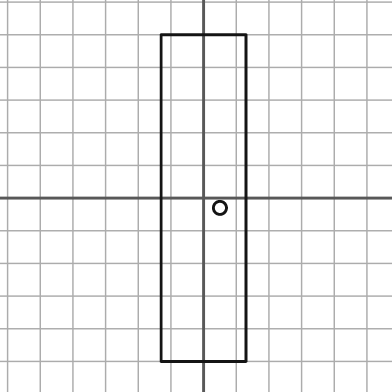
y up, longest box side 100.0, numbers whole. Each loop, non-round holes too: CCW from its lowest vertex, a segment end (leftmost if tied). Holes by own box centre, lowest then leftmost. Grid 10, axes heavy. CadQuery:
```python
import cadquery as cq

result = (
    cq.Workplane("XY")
    .moveTo(-13.0, -50.0)
    .lineTo(13.0, -50.0)
    .lineTo(13.0, 50.0)
    .lineTo(-13.0, 50.0)
    .close()
    .moveTo(5.0, -3.0)
    .circle(2.0)
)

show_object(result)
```